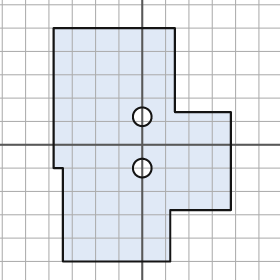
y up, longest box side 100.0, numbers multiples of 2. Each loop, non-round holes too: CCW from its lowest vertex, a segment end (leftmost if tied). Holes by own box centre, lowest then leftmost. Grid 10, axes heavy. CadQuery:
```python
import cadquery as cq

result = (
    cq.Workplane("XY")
    .moveTo(-34.0, -50.0)
    .lineTo(12.0, -50.0)
    .lineTo(12.0, -28.0)
    .lineTo(38.0, -28.0)
    .lineTo(38.0, 14.0)
    .lineTo(14.0, 14.0)
    .lineTo(14.0, 50.0)
    .lineTo(-38.0, 50.0)
    .lineTo(-38.0, -10.0)
    .lineTo(-34.0, -10.0)
    .close()
    .moveTo(0.0, -10.0)
    .circle(4.0)
    .moveTo(0.0, 12.0)
    .circle(4.0)
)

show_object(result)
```